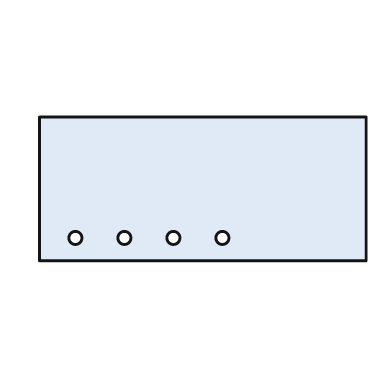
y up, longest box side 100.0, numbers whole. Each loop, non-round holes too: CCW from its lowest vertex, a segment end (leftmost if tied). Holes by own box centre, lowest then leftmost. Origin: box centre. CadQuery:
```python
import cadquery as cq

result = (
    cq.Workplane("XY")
    .moveTo(-50.0, -22.0)
    .lineTo(50.0, -22.0)
    .lineTo(50.0, 22.0)
    .lineTo(-50.0, 22.0)
    .close()
    .moveTo(-39.0, -15.0)
    .circle(2.0)
    .moveTo(-24.0, -15.0)
    .circle(2.0)
    .moveTo(-9.0, -15.0)
    .circle(2.0)
    .moveTo(6.0, -15.0)
    .circle(2.0)
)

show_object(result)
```